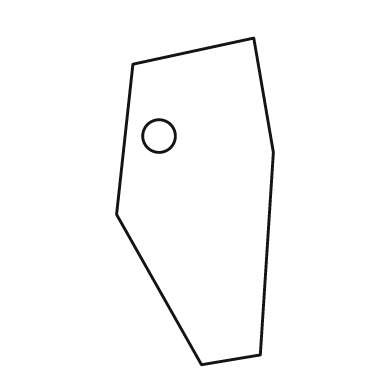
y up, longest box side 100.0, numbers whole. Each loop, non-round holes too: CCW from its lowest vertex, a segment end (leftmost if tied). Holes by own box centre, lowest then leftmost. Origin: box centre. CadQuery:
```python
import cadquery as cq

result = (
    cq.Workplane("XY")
    .moveTo(2.0, -50.0)
    .lineTo(20.0, -47.0)
    .lineTo(24.0, 15.0)
    .lineTo(18.0, 50.0)
    .lineTo(-19.0, 42.0)
    .lineTo(-24.0, -4.0)
    .close()
    .moveTo(-11.0, 20.0)
    .circle(5.0)
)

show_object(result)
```